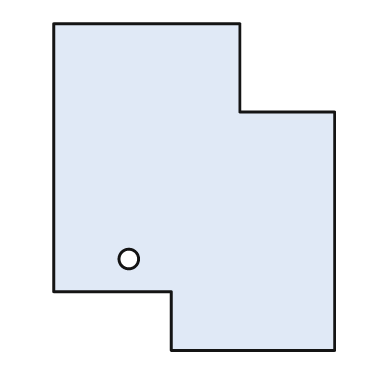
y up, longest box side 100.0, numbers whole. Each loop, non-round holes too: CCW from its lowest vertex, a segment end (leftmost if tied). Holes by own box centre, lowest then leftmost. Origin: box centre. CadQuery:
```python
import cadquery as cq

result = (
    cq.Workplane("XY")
    .moveTo(-7.0, -50.0)
    .lineTo(43.0, -50.0)
    .lineTo(43.0, 23.0)
    .lineTo(14.0, 23.0)
    .lineTo(14.0, 50.0)
    .lineTo(-43.0, 50.0)
    .lineTo(-43.0, -32.0)
    .lineTo(-7.0, -32.0)
    .close()
    .moveTo(-20.0, -22.0)
    .circle(3.0)
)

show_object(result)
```